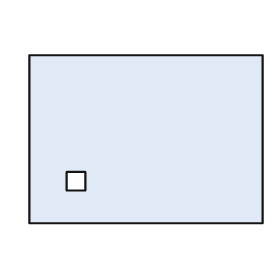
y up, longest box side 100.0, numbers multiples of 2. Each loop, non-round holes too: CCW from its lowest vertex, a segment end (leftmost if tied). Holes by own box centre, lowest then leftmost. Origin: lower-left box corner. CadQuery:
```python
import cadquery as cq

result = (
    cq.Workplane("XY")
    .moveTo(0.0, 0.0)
    .lineTo(100.0, 0.0)
    .lineTo(100.0, 72.0)
    .lineTo(0.0, 72.0)
    .close()
    .moveTo(16.0, 14.0)
    .lineTo(24.0, 14.0)
    .lineTo(24.0, 22.0)
    .lineTo(16.0, 22.0)
    .close()
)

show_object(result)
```